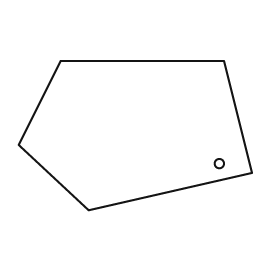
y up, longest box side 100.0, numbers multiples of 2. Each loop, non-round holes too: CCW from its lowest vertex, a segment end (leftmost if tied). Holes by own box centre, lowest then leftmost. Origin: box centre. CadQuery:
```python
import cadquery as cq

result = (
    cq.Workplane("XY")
    .moveTo(-20.0, -32.0)
    .lineTo(50.0, -16.0)
    .lineTo(38.0, 32.0)
    .lineTo(-32.0, 32.0)
    .lineTo(-50.0, -4.0)
    .close()
    .moveTo(36.0, -12.0)
    .circle(2.0)
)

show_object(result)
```